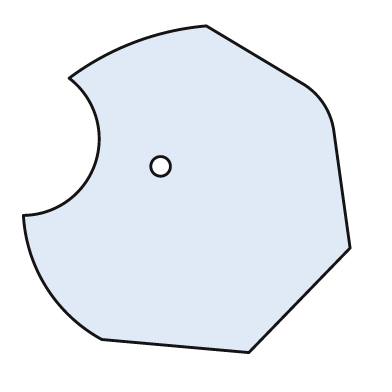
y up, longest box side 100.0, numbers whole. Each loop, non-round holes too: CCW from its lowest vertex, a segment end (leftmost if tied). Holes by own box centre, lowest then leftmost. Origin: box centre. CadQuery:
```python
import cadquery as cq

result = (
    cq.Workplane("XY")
    .moveTo(19.0, -50.0)
    .lineTo(50.0, -18.0)
    .lineTo(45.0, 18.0)
    .threePointArc((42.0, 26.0), (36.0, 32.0))
    .lineTo(6.0, 50.0)
    .threePointArc((-16.0, 45.0), (-36.0, 34.0))
    .threePointArc((-28.0, 8.0), (-50.0, -8.0))
    .threePointArc((-43.0, -30.0), (-26.0, -46.0))
    .close()
    .moveTo(-8.0, 7.0)
    .circle(3.0)
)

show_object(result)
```